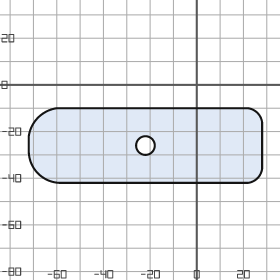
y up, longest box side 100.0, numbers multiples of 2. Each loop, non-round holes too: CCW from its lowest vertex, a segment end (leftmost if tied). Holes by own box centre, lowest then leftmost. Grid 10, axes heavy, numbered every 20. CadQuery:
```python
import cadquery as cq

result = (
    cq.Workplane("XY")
    .moveTo(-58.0, -42.0)
    .lineTo(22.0, -42.0)
    .threePointArc((26.0, -40.0), (28.0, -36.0))
    .lineTo(28.0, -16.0)
    .threePointArc((26.0, -12.0), (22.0, -10.0))
    .lineTo(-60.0, -10.0)
    .threePointArc((-68.0, -14.0), (-72.0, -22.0))
    .lineTo(-72.0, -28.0)
    .threePointArc((-68.0, -38.0), (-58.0, -42.0))
    .close()
    .moveTo(-22.0, -26.0)
    .circle(4.0)
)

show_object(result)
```